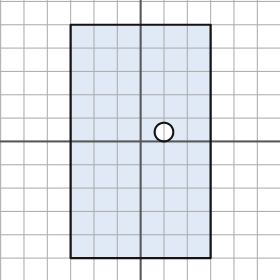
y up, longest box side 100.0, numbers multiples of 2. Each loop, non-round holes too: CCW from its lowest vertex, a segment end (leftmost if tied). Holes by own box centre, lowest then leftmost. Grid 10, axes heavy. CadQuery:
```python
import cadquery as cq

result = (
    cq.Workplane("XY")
    .moveTo(-30.0, -50.0)
    .lineTo(30.0, -50.0)
    .lineTo(30.0, 50.0)
    .lineTo(-30.0, 50.0)
    .close()
    .moveTo(10.0, 4.0)
    .circle(4.0)
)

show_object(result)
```